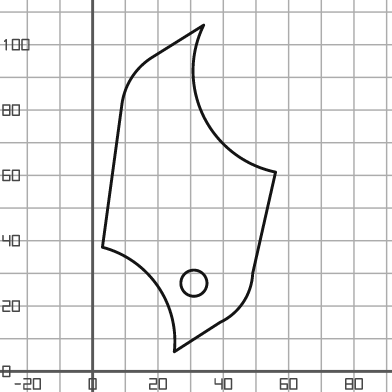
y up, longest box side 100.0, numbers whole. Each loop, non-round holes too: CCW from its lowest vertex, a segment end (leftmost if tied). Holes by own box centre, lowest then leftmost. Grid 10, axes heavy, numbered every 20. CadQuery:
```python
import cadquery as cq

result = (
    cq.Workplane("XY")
    .moveTo(25.0, 6.0)
    .lineTo(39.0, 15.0)
    .threePointArc((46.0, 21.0), (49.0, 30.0))
    .lineTo(56.0, 61.0)
    .threePointArc((34.0, 78.0), (34.0, 106.0))
    .lineTo(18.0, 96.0)
    .threePointArc((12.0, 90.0), (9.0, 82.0))
    .lineTo(3.0, 38.0)
    .threePointArc((20.0, 26.0), (25.0, 6.0))
    .close()
    .moveTo(31.0, 27.0)
    .circle(4.0)
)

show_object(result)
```